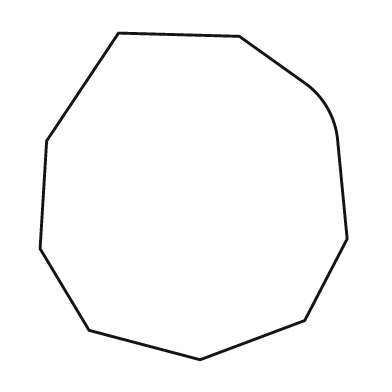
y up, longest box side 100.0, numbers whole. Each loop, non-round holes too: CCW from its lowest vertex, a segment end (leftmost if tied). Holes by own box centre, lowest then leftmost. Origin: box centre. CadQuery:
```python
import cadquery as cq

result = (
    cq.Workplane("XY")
    .moveTo(2.0, -50.0)
    .lineTo(34.0, -38.0)
    .lineTo(47.0, -13.0)
    .lineTo(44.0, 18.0)
    .threePointArc((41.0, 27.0), (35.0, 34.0))
    .lineTo(14.0, 49.0)
    .lineTo(-23.0, 50.0)
    .lineTo(-45.0, 17.0)
    .lineTo(-47.0, -16.0)
    .lineTo(-32.0, -41.0)
    .close()
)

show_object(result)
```